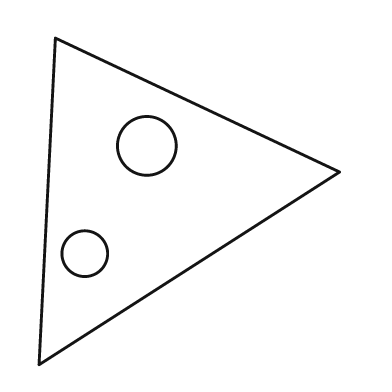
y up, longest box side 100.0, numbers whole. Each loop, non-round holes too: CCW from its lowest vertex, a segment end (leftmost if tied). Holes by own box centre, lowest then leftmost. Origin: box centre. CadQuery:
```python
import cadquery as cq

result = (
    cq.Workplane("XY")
    .moveTo(-46.0, -50.0)
    .lineTo(46.0, 9.0)
    .lineTo(-41.0, 50.0)
    .close()
    .moveTo(-32.0, -16.0)
    .circle(7.0)
    .moveTo(-13.0, 17.0)
    .circle(9.0)
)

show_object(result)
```